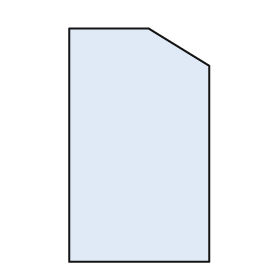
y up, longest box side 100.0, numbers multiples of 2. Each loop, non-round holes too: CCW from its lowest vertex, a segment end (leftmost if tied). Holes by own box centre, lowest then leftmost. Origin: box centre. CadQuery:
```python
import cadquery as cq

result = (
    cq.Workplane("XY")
    .moveTo(-30.0, -50.0)
    .lineTo(30.0, -50.0)
    .lineTo(30.0, 34.0)
    .lineTo(4.0, 50.0)
    .lineTo(-30.0, 50.0)
    .close()
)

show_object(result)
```